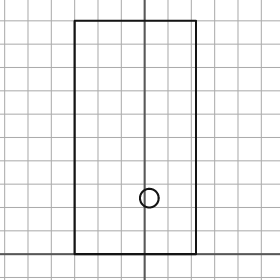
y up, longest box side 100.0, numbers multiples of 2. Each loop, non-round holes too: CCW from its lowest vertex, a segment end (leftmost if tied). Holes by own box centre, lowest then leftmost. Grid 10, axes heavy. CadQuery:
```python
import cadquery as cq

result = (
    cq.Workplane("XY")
    .moveTo(-30.0, 0.0)
    .lineTo(22.0, 0.0)
    .lineTo(22.0, 100.0)
    .lineTo(-30.0, 100.0)
    .close()
    .moveTo(2.0, 24.0)
    .circle(4.0)
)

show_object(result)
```